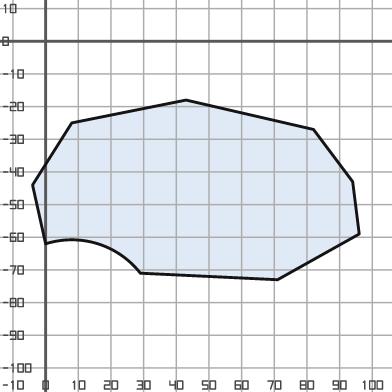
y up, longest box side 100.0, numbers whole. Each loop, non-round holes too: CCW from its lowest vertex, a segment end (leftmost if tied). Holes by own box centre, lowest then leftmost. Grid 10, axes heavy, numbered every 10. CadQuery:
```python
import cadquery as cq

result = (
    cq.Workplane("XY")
    .moveTo(71.0, -73.0)
    .lineTo(96.0, -59.0)
    .lineTo(94.0, -43.0)
    .lineTo(82.0, -27.0)
    .lineTo(43.0, -18.0)
    .lineTo(8.0, -25.0)
    .lineTo(-4.0, -44.0)
    .lineTo(0.0, -62.0)
    .threePointArc((16.0, -62.0), (29.0, -71.0))
    .close()
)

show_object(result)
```